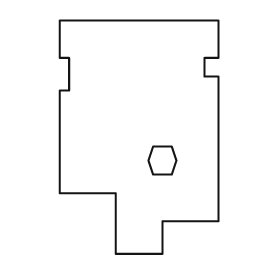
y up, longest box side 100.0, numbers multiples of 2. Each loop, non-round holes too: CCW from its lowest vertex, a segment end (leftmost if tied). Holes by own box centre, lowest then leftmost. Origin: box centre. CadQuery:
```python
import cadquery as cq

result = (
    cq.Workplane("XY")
    .moveTo(-10.0, -50.0)
    .lineTo(10.0, -50.0)
    .lineTo(10.0, -36.0)
    .lineTo(34.0, -36.0)
    .lineTo(34.0, 26.0)
    .lineTo(28.0, 26.0)
    .lineTo(28.0, 34.0)
    .lineTo(34.0, 34.0)
    .lineTo(34.0, 50.0)
    .lineTo(-34.0, 50.0)
    .lineTo(-34.0, 34.0)
    .lineTo(-30.0, 34.0)
    .lineTo(-30.0, 20.0)
    .lineTo(-34.0, 20.0)
    .lineTo(-34.0, -24.0)
    .lineTo(-10.0, -24.0)
    .close()
    .moveTo(6.0, -16.0)
    .lineTo(14.0, -16.0)
    .lineTo(16.0, -10.0)
    .lineTo(14.0, -4.0)
    .lineTo(6.0, -4.0)
    .lineTo(4.0, -10.0)
    .close()
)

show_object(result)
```